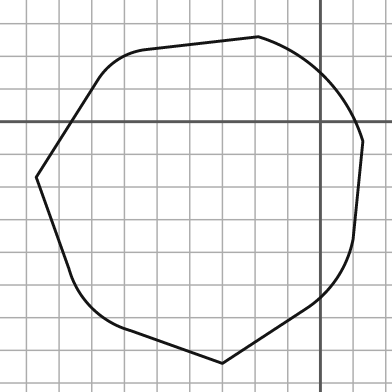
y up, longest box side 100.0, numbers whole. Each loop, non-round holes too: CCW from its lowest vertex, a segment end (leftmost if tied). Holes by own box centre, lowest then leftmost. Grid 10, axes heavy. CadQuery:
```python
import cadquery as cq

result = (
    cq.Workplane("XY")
    .moveTo(-30.0, -74.0)
    .lineTo(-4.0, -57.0)
    .threePointArc((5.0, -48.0), (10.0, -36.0))
    .lineTo(13.0, -6.0)
    .threePointArc((1.0, 14.0), (-19.0, 26.0))
    .lineTo(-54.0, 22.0)
    .threePointArc((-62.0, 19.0), (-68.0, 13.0))
    .lineTo(-87.0, -17.0)
    .lineTo(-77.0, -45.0)
    .threePointArc((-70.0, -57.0), (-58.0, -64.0))
    .close()
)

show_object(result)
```